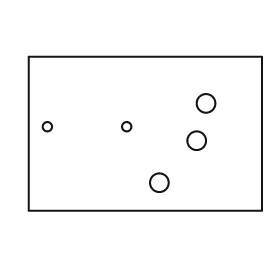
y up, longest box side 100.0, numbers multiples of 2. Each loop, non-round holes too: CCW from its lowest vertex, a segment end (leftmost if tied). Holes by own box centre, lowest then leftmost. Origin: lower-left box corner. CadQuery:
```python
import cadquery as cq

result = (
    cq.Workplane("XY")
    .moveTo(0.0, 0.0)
    .lineTo(100.0, 0.0)
    .lineTo(100.0, 66.0)
    .lineTo(0.0, 66.0)
    .close()
    .moveTo(56.0, 12.0)
    .circle(4.0)
    .moveTo(72.0, 30.0)
    .circle(4.0)
    .moveTo(8.0, 36.0)
    .circle(2.0)
    .moveTo(42.0, 36.0)
    .circle(2.0)
    .moveTo(76.0, 46.0)
    .circle(4.0)
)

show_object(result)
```